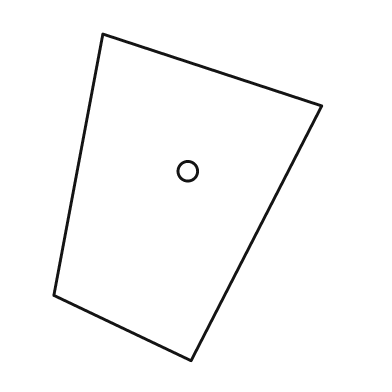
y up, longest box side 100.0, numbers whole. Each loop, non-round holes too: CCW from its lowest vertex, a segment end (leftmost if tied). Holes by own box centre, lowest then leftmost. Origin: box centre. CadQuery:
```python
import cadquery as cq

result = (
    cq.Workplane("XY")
    .moveTo(1.0, -50.0)
    .lineTo(41.0, 28.0)
    .lineTo(-26.0, 50.0)
    .lineTo(-41.0, -30.0)
    .close()
    .moveTo(0.0, 8.0)
    .circle(3.0)
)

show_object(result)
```